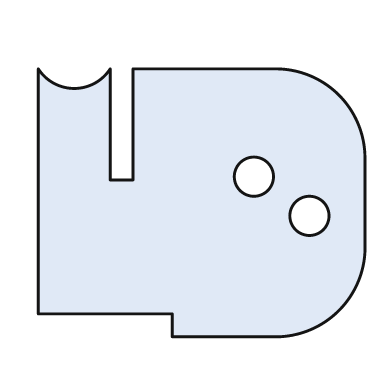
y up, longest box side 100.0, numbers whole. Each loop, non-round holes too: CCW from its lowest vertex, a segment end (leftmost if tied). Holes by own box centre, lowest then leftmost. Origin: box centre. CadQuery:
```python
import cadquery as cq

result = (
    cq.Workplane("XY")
    .moveTo(-9.0, -41.0)
    .lineTo(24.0, -41.0)
    .threePointArc((42.0, -33.0), (50.0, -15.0))
    .lineTo(50.0, 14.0)
    .threePointArc((42.0, 33.0), (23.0, 41.0))
    .lineTo(-21.0, 41.0)
    .lineTo(-21.0, 7.0)
    .lineTo(-28.0, 7.0)
    .lineTo(-28.0, 41.0)
    .threePointArc((-39.0, 35.0), (-50.0, 41.0))
    .lineTo(-50.0, -34.0)
    .lineTo(-9.0, -34.0)
    .close()
    .moveTo(33.0, -4.0)
    .circle(6.0)
    .moveTo(16.0, 8.0)
    .circle(6.0)
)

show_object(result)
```